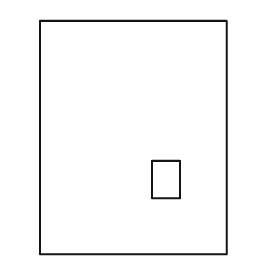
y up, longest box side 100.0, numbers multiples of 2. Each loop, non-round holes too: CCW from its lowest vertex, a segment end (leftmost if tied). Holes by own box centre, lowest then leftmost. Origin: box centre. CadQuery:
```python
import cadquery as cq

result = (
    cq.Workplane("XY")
    .moveTo(-40.0, -50.0)
    .lineTo(40.0, -50.0)
    .lineTo(40.0, 50.0)
    .lineTo(-40.0, 50.0)
    .close()
    .moveTo(8.0, -26.0)
    .lineTo(20.0, -26.0)
    .lineTo(20.0, -10.0)
    .lineTo(8.0, -10.0)
    .close()
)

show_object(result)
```